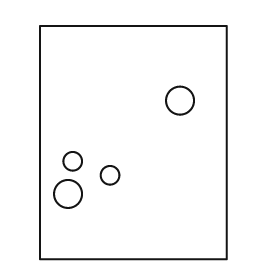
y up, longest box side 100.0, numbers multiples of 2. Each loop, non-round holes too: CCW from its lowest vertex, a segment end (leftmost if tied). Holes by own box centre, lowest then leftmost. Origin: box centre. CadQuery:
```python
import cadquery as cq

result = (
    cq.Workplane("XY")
    .moveTo(-40.0, -50.0)
    .lineTo(40.0, -50.0)
    .lineTo(40.0, 50.0)
    .lineTo(-40.0, 50.0)
    .close()
    .moveTo(-28.0, -22.0)
    .circle(6.0)
    .moveTo(-10.0, -14.0)
    .circle(4.0)
    .moveTo(-26.0, -8.0)
    .circle(4.0)
    .moveTo(20.0, 18.0)
    .circle(6.0)
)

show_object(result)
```